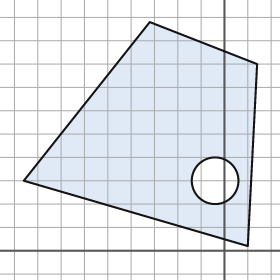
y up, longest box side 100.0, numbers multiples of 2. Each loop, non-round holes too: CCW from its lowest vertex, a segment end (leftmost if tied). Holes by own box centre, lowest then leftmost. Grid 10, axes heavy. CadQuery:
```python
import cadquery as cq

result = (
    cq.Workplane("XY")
    .moveTo(10.0, 2.0)
    .lineTo(14.0, 80.0)
    .lineTo(-32.0, 98.0)
    .lineTo(-86.0, 30.0)
    .close()
    .moveTo(-4.0, 30.0)
    .circle(10.0)
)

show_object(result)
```